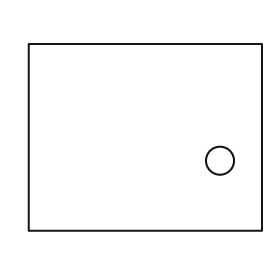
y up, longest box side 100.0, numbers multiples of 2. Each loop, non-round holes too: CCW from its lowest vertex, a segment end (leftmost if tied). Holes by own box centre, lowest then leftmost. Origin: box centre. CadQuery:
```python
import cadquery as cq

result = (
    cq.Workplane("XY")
    .moveTo(-50.0, -40.0)
    .lineTo(50.0, -40.0)
    .lineTo(50.0, 40.0)
    .lineTo(-50.0, 40.0)
    .close()
    .moveTo(32.0, -10.0)
    .circle(6.0)
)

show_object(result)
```